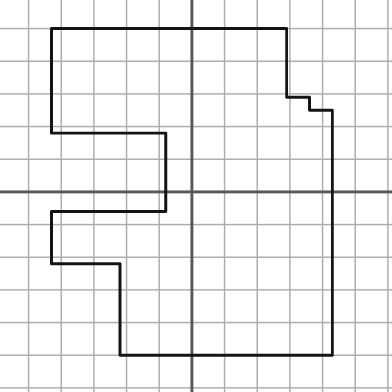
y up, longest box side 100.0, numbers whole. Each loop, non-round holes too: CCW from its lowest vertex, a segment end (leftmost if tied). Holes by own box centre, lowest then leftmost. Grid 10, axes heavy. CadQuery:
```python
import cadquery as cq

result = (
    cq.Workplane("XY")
    .moveTo(-22.0, -50.0)
    .lineTo(43.0, -50.0)
    .lineTo(43.0, 25.0)
    .lineTo(36.0, 25.0)
    .lineTo(36.0, 29.0)
    .lineTo(29.0, 29.0)
    .lineTo(29.0, 50.0)
    .lineTo(-43.0, 50.0)
    .lineTo(-43.0, 18.0)
    .lineTo(-8.0, 18.0)
    .lineTo(-8.0, -6.0)
    .lineTo(-43.0, -6.0)
    .lineTo(-43.0, -22.0)
    .lineTo(-22.0, -22.0)
    .close()
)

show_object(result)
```